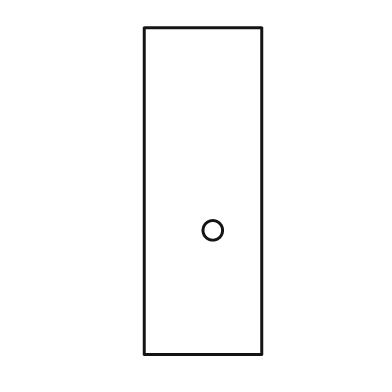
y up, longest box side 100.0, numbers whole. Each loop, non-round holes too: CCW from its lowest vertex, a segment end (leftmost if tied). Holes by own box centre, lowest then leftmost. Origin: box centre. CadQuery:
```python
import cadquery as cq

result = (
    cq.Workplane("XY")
    .moveTo(-18.0, -50.0)
    .lineTo(18.0, -50.0)
    .lineTo(18.0, 50.0)
    .lineTo(-18.0, 50.0)
    .close()
    .moveTo(3.0, -12.0)
    .circle(3.0)
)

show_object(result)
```